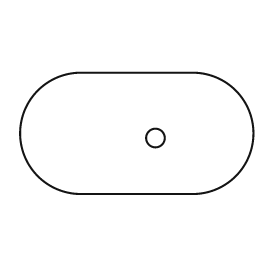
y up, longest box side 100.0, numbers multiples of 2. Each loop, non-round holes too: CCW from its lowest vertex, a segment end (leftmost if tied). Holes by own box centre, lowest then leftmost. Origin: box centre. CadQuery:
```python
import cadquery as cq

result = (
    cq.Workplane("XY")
    .moveTo(-24.0, -26.0)
    .lineTo(24.0, -26.0)
    .threePointArc((50.0, 0.0), (24.0, 26.0))
    .lineTo(-24.0, 26.0)
    .threePointArc((-50.0, 0.0), (-24.0, -26.0))
    .close()
    .moveTo(8.0, -2.0)
    .circle(4.0)
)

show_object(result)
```